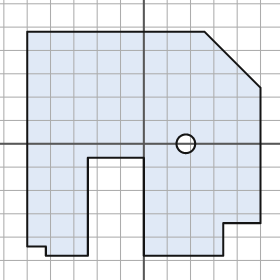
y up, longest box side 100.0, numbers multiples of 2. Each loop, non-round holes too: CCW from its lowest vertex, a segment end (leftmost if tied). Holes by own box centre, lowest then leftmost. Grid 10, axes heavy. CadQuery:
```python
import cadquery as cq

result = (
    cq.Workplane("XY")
    .moveTo(-42.0, -48.0)
    .lineTo(-24.0, -48.0)
    .lineTo(-24.0, -6.0)
    .lineTo(0.0, -6.0)
    .lineTo(0.0, -48.0)
    .lineTo(34.0, -48.0)
    .lineTo(34.0, -34.0)
    .lineTo(50.0, -34.0)
    .lineTo(50.0, 24.0)
    .lineTo(26.0, 48.0)
    .lineTo(-50.0, 48.0)
    .lineTo(-50.0, -44.0)
    .lineTo(-42.0, -44.0)
    .close()
    .moveTo(18.0, 0.0)
    .circle(4.0)
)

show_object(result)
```